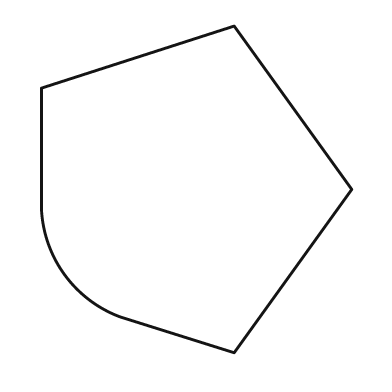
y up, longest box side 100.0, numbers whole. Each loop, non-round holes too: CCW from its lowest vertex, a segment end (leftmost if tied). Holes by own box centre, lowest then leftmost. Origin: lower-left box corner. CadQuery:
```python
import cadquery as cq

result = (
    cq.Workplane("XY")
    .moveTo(59.0, 0.0)
    .lineTo(95.0, 50.0)
    .lineTo(59.0, 100.0)
    .lineTo(0.0, 81.0)
    .lineTo(0.0, 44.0)
    .threePointArc((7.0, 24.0), (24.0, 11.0))
    .close()
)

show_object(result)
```